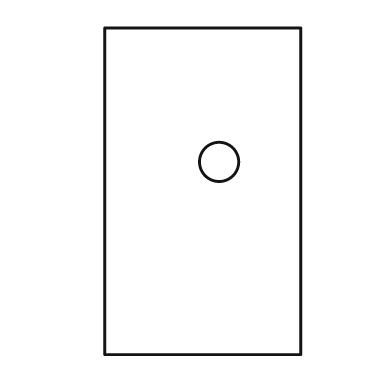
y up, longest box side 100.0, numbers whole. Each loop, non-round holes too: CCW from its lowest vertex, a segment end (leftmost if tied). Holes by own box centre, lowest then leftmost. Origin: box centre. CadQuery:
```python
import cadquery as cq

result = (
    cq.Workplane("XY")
    .moveTo(-30.0, -50.0)
    .lineTo(30.0, -50.0)
    .lineTo(30.0, 50.0)
    .lineTo(-30.0, 50.0)
    .close()
    .moveTo(5.0, 9.0)
    .circle(6.0)
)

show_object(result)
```